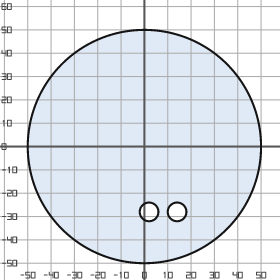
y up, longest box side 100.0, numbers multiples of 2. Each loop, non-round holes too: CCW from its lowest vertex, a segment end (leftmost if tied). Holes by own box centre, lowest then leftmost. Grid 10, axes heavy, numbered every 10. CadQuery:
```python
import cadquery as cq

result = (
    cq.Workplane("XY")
    .moveTo(0.0, 0.0)
    .circle(50.0)
    .moveTo(2.0, -28.0)
    .circle(4.0)
    .moveTo(14.0, -28.0)
    .circle(4.0)
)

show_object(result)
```